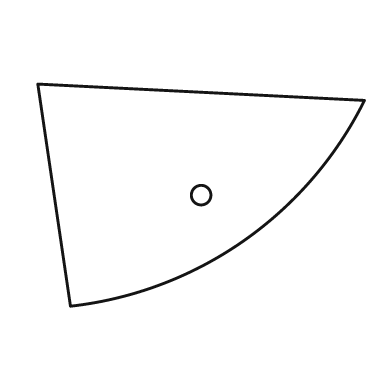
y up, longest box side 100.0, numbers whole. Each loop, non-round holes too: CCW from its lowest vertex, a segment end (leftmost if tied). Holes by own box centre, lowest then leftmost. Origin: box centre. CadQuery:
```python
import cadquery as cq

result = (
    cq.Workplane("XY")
    .moveTo(-40.0, -34.0)
    .threePointArc((13.0, -14.0), (50.0, 29.0))
    .lineTo(-50.0, 34.0)
    .close()
    .moveTo(0.0, 0.0)
    .circle(3.0)
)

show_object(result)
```